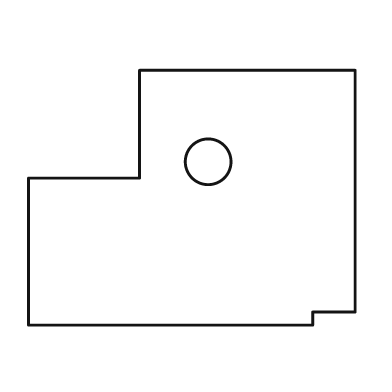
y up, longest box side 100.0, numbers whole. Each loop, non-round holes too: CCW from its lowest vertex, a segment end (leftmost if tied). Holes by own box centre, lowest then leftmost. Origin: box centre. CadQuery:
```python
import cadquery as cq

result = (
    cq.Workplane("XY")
    .moveTo(-50.0, -39.0)
    .lineTo(37.0, -39.0)
    .lineTo(37.0, -35.0)
    .lineTo(50.0, -35.0)
    .lineTo(50.0, 39.0)
    .lineTo(-16.0, 39.0)
    .lineTo(-16.0, 6.0)
    .lineTo(-50.0, 6.0)
    .close()
    .moveTo(5.0, 11.0)
    .circle(7.0)
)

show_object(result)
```